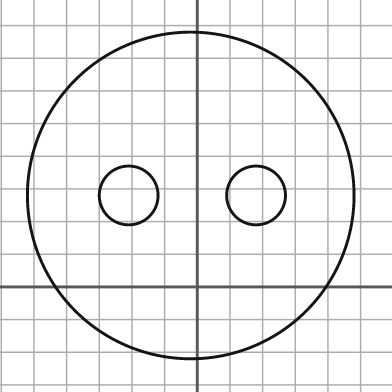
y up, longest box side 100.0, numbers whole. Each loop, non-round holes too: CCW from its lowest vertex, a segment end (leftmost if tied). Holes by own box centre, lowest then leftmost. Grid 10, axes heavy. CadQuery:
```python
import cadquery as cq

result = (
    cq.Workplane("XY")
    .moveTo(-2.0, 28.0)
    .circle(50.0)
    .moveTo(-21.0, 28.0)
    .circle(9.0)
    .moveTo(18.0, 28.0)
    .circle(9.0)
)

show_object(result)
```